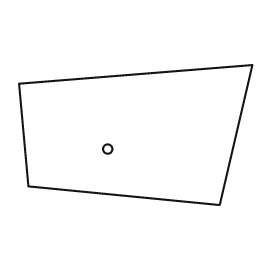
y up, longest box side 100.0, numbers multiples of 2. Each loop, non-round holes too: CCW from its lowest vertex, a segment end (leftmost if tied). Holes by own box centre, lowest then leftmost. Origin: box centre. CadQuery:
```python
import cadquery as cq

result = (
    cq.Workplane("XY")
    .moveTo(36.0, -30.0)
    .lineTo(50.0, 30.0)
    .lineTo(-50.0, 22.0)
    .lineTo(-46.0, -22.0)
    .close()
    .moveTo(-12.0, -6.0)
    .circle(2.0)
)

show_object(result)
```